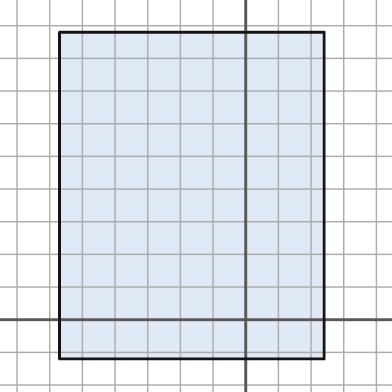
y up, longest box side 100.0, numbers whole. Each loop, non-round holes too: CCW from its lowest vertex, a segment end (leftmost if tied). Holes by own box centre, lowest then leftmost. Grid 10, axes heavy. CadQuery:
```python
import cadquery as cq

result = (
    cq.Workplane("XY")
    .moveTo(-57.0, -12.0)
    .lineTo(24.0, -12.0)
    .lineTo(24.0, 88.0)
    .lineTo(-57.0, 88.0)
    .close()
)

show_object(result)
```